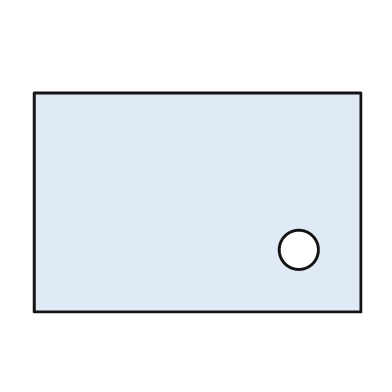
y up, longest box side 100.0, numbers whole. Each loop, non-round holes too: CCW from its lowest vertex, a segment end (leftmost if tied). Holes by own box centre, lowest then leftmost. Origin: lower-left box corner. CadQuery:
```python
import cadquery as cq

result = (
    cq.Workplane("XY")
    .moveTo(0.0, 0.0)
    .lineTo(100.0, 0.0)
    .lineTo(100.0, 67.0)
    .lineTo(0.0, 67.0)
    .close()
    .moveTo(81.0, 19.0)
    .circle(6.0)
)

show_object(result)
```